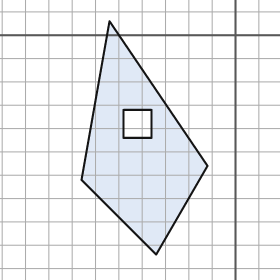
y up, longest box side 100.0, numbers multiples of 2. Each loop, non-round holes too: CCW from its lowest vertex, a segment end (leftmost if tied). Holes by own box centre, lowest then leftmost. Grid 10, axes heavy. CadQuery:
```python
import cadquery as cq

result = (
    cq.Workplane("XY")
    .moveTo(-34.0, -94.0)
    .lineTo(-12.0, -56.0)
    .lineTo(-54.0, 6.0)
    .lineTo(-66.0, -62.0)
    .close()
    .moveTo(-48.0, -44.0)
    .lineTo(-36.0, -44.0)
    .lineTo(-36.0, -32.0)
    .lineTo(-48.0, -32.0)
    .close()
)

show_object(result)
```